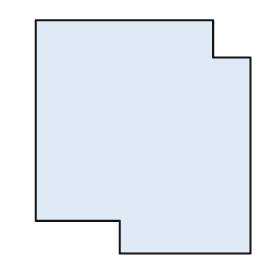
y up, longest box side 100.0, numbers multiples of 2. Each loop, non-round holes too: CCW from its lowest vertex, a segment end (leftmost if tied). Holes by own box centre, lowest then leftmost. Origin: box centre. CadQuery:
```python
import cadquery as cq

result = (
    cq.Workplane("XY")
    .moveTo(-10.0, -50.0)
    .lineTo(46.0, -50.0)
    .lineTo(46.0, 34.0)
    .lineTo(30.0, 34.0)
    .lineTo(30.0, 50.0)
    .lineTo(-46.0, 50.0)
    .lineTo(-46.0, -36.0)
    .lineTo(-10.0, -36.0)
    .close()
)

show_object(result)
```